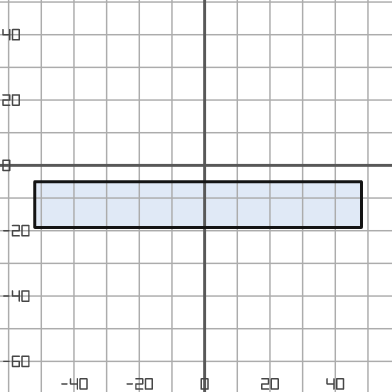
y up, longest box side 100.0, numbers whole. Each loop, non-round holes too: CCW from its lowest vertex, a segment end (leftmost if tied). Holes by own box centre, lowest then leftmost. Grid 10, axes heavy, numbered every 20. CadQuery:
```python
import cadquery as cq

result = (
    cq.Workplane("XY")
    .moveTo(-52.0, -19.0)
    .lineTo(48.0, -19.0)
    .lineTo(48.0, -5.0)
    .lineTo(-52.0, -5.0)
    .close()
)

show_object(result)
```